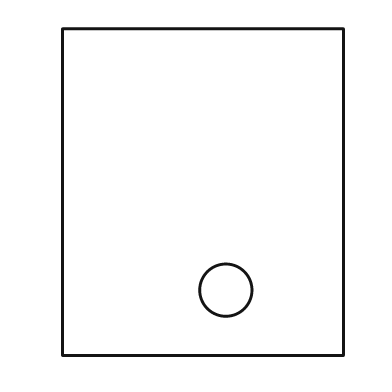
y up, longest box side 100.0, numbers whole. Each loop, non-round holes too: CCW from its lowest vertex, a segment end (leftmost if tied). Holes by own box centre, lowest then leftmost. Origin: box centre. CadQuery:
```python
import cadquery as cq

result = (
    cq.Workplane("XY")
    .moveTo(-43.0, -50.0)
    .lineTo(43.0, -50.0)
    .lineTo(43.0, 50.0)
    .lineTo(-43.0, 50.0)
    .close()
    .moveTo(7.0, -30.0)
    .circle(8.0)
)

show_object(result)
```